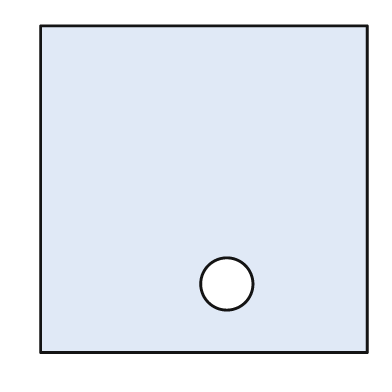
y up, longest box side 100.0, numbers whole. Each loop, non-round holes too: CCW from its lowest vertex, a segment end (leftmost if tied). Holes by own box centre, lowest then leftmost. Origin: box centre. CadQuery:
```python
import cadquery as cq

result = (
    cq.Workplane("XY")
    .moveTo(-50.0, -50.0)
    .lineTo(50.0, -50.0)
    .lineTo(50.0, 50.0)
    .lineTo(-50.0, 50.0)
    .close()
    .moveTo(7.0, -29.0)
    .circle(8.0)
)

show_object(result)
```